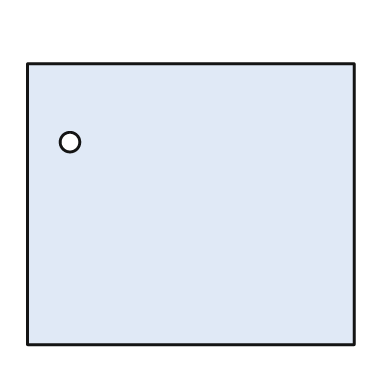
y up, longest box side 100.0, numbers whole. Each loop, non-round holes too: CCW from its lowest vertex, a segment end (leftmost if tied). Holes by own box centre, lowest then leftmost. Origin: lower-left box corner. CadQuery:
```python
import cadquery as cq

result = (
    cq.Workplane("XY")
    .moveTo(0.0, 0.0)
    .lineTo(100.0, 0.0)
    .lineTo(100.0, 86.0)
    .lineTo(0.0, 86.0)
    .close()
    .moveTo(13.0, 62.0)
    .circle(3.0)
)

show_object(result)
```